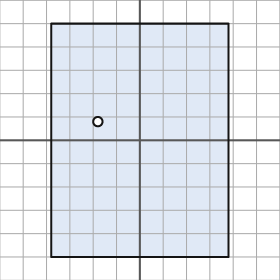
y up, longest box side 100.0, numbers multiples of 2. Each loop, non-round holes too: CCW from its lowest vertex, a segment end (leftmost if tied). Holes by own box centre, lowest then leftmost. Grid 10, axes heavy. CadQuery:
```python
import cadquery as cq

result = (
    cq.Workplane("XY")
    .moveTo(-38.0, -50.0)
    .lineTo(38.0, -50.0)
    .lineTo(38.0, 50.0)
    .lineTo(-38.0, 50.0)
    .close()
    .moveTo(-18.0, 8.0)
    .circle(2.0)
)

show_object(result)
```